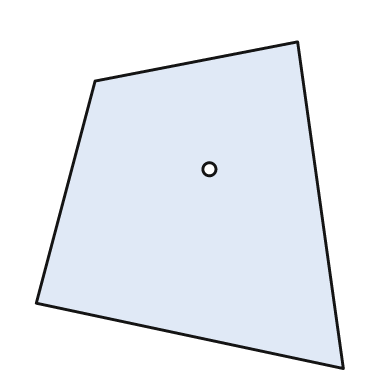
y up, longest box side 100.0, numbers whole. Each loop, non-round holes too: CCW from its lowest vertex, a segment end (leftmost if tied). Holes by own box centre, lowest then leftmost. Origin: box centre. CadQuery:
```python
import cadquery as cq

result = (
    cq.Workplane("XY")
    .moveTo(47.0, -50.0)
    .lineTo(33.0, 50.0)
    .lineTo(-29.0, 38.0)
    .lineTo(-47.0, -30.0)
    .close()
    .moveTo(6.0, 11.0)
    .circle(2.0)
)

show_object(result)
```